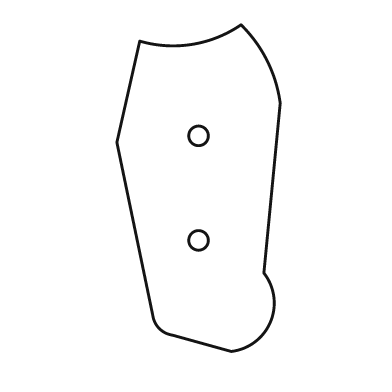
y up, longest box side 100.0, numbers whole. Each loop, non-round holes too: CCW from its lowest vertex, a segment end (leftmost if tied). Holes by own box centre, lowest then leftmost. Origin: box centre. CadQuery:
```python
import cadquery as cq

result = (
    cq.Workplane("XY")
    .moveTo(10.0, -50.0)
    .threePointArc((22.0, -41.0), (20.0, -26.0))
    .lineTo(25.0, 26.0)
    .threePointArc((21.0, 39.0), (13.0, 50.0))
    .threePointArc((-2.0, 44.0), (-18.0, 45.0))
    .lineTo(-25.0, 14.0)
    .lineTo(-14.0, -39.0)
    .threePointArc((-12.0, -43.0), (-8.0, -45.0))
    .close()
    .moveTo(0.0, -16.0)
    .circle(3.0)
    .moveTo(0.0, 16.0)
    .circle(3.0)
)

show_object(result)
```